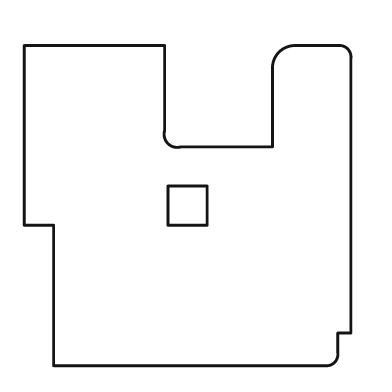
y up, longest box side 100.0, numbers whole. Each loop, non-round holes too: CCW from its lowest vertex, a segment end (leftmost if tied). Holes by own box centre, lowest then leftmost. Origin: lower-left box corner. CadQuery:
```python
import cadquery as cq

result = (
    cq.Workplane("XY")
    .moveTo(9.0, 0.0)
    .lineTo(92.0, 0.0)
    .threePointArc((95.0, 1.0), (96.0, 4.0))
    .lineTo(96.0, 10.0)
    .lineTo(100.0, 10.0)
    .lineTo(100.0, 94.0)
    .threePointArc((99.0, 97.0), (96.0, 98.0))
    .lineTo(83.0, 98.0)
    .threePointArc((78.0, 96.0), (76.0, 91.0))
    .lineTo(76.0, 67.0)
    .lineTo(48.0, 67.0)
    .threePointArc((44.0, 68.0), (43.0, 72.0))
    .lineTo(43.0, 98.0)
    .lineTo(0.0, 98.0)
    .lineTo(0.0, 43.0)
    .lineTo(9.0, 43.0)
    .close()
    .moveTo(44.0, 43.0)
    .lineTo(56.0, 43.0)
    .lineTo(56.0, 55.0)
    .lineTo(44.0, 55.0)
    .close()
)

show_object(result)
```